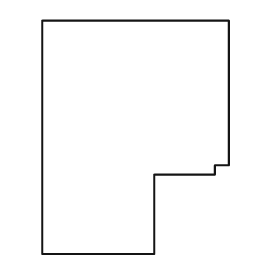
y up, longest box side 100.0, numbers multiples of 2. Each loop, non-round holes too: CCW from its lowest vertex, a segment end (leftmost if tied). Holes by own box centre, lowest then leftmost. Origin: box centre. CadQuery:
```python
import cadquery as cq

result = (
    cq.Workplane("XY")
    .moveTo(-40.0, -50.0)
    .lineTo(8.0, -50.0)
    .lineTo(8.0, -16.0)
    .lineTo(34.0, -16.0)
    .lineTo(34.0, -12.0)
    .lineTo(40.0, -12.0)
    .lineTo(40.0, 50.0)
    .lineTo(-40.0, 50.0)
    .close()
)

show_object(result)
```